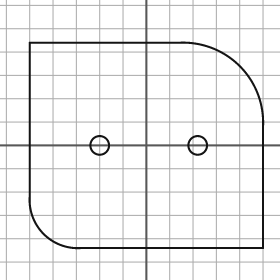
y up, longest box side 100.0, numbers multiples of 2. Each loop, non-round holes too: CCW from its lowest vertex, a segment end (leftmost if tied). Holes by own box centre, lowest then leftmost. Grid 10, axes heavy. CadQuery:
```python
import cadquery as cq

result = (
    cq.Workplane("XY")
    .moveTo(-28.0, -44.0)
    .lineTo(50.0, -44.0)
    .lineTo(50.0, 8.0)
    .threePointArc((40.0, 34.0), (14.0, 44.0))
    .lineTo(-50.0, 44.0)
    .lineTo(-50.0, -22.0)
    .threePointArc((-44.0, -38.0), (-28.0, -44.0))
    .close()
    .moveTo(-20.0, 0.0)
    .circle(4.0)
    .moveTo(22.0, 0.0)
    .circle(4.0)
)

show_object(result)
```